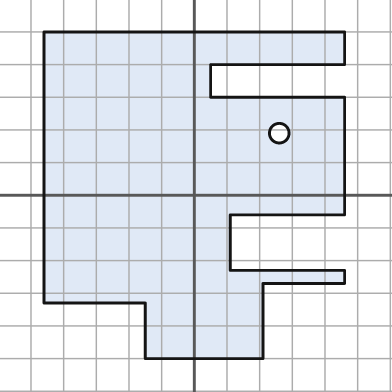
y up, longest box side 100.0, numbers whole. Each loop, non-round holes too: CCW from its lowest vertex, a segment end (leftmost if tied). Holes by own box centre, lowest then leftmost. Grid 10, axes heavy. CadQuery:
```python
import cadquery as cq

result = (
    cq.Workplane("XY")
    .moveTo(-15.0, -50.0)
    .lineTo(21.0, -50.0)
    .lineTo(21.0, -27.0)
    .lineTo(46.0, -27.0)
    .lineTo(46.0, -23.0)
    .lineTo(11.0, -23.0)
    .lineTo(11.0, -6.0)
    .lineTo(46.0, -6.0)
    .lineTo(46.0, 30.0)
    .lineTo(5.0, 30.0)
    .lineTo(5.0, 40.0)
    .lineTo(46.0, 40.0)
    .lineTo(46.0, 50.0)
    .lineTo(-46.0, 50.0)
    .lineTo(-46.0, -33.0)
    .lineTo(-15.0, -33.0)
    .close()
    .moveTo(26.0, 19.0)
    .circle(3.0)
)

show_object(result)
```